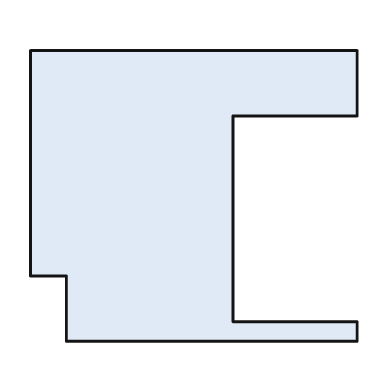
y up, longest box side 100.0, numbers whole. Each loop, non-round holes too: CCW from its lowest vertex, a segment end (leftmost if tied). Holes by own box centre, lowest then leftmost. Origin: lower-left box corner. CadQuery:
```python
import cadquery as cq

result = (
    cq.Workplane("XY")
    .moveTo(11.0, 0.0)
    .lineTo(100.0, 0.0)
    .lineTo(100.0, 6.0)
    .lineTo(62.0, 6.0)
    .lineTo(62.0, 69.0)
    .lineTo(100.0, 69.0)
    .lineTo(100.0, 89.0)
    .lineTo(0.0, 89.0)
    .lineTo(0.0, 20.0)
    .lineTo(11.0, 20.0)
    .close()
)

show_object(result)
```